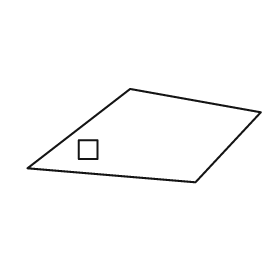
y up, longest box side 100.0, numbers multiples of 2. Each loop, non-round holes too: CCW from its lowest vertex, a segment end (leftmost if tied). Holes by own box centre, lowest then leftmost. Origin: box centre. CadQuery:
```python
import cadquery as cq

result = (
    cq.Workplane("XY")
    .moveTo(22.0, -20.0)
    .lineTo(50.0, 10.0)
    .lineTo(-6.0, 20.0)
    .lineTo(-50.0, -14.0)
    .close()
    .moveTo(-28.0, -10.0)
    .lineTo(-20.0, -10.0)
    .lineTo(-20.0, -2.0)
    .lineTo(-28.0, -2.0)
    .close()
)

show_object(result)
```